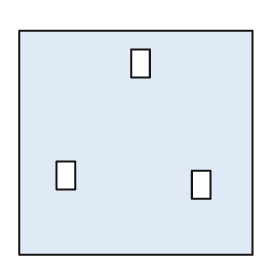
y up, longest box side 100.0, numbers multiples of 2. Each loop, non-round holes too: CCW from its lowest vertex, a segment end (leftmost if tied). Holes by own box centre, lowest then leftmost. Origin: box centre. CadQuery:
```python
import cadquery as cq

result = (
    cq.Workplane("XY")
    .moveTo(-50.0, -48.0)
    .lineTo(50.0, -48.0)
    .lineTo(50.0, 48.0)
    .lineTo(-50.0, 48.0)
    .close()
    .moveTo(24.0, -24.0)
    .lineTo(32.0, -24.0)
    .lineTo(32.0, -12.0)
    .lineTo(24.0, -12.0)
    .close()
    .moveTo(-34.0, -20.0)
    .lineTo(-26.0, -20.0)
    .lineTo(-26.0, -8.0)
    .lineTo(-34.0, -8.0)
    .close()
    .moveTo(-2.0, 28.0)
    .lineTo(6.0, 28.0)
    .lineTo(6.0, 40.0)
    .lineTo(-2.0, 40.0)
    .close()
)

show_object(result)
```